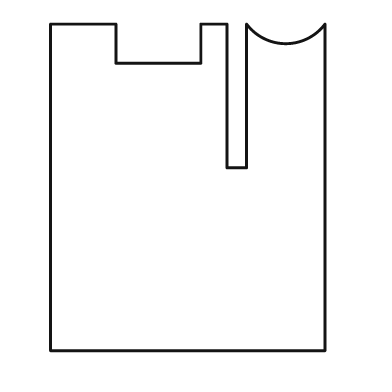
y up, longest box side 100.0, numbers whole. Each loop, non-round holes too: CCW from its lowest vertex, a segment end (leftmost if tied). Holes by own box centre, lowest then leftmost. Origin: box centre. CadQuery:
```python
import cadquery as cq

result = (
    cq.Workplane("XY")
    .moveTo(-42.0, -50.0)
    .lineTo(42.0, -50.0)
    .lineTo(42.0, 50.0)
    .threePointArc((30.0, 44.0), (18.0, 50.0))
    .lineTo(18.0, 6.0)
    .lineTo(12.0, 6.0)
    .lineTo(12.0, 50.0)
    .lineTo(4.0, 50.0)
    .lineTo(4.0, 38.0)
    .lineTo(-22.0, 38.0)
    .lineTo(-22.0, 50.0)
    .lineTo(-42.0, 50.0)
    .close()
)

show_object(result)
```